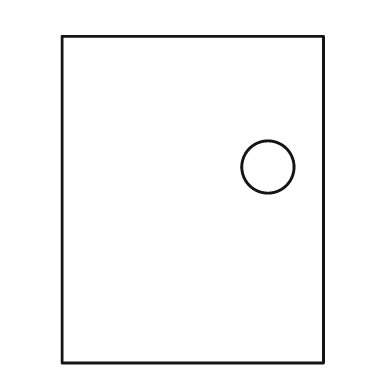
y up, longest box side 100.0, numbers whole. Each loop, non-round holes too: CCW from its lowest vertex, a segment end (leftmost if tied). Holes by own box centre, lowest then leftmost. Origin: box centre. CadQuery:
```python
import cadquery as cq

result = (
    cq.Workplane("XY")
    .moveTo(-40.0, -50.0)
    .lineTo(40.0, -50.0)
    .lineTo(40.0, 50.0)
    .lineTo(-40.0, 50.0)
    .close()
    .moveTo(23.0, 10.0)
    .circle(8.0)
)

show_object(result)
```